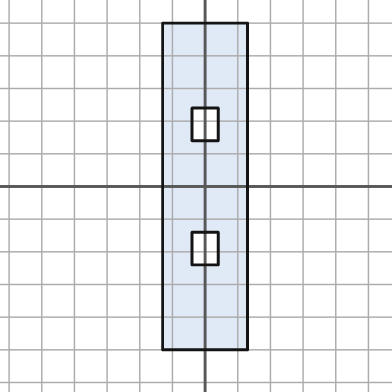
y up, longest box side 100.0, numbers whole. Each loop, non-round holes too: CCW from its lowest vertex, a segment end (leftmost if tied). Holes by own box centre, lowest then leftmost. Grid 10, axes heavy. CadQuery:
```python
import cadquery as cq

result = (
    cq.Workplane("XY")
    .moveTo(-13.0, -50.0)
    .lineTo(13.0, -50.0)
    .lineTo(13.0, 50.0)
    .lineTo(-13.0, 50.0)
    .close()
    .moveTo(-4.0, -24.0)
    .lineTo(4.0, -24.0)
    .lineTo(4.0, -14.0)
    .lineTo(-4.0, -14.0)
    .close()
    .moveTo(-4.0, 14.0)
    .lineTo(4.0, 14.0)
    .lineTo(4.0, 24.0)
    .lineTo(-4.0, 24.0)
    .close()
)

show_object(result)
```